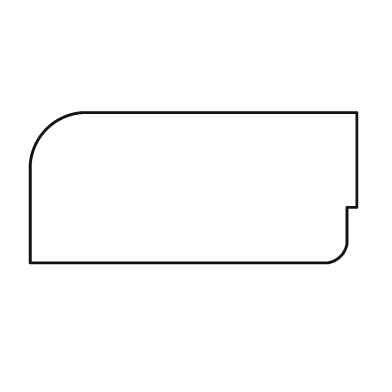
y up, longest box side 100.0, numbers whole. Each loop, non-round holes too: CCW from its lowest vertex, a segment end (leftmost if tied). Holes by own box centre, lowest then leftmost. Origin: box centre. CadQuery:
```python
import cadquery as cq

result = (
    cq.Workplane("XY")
    .moveTo(-50.0, -23.0)
    .lineTo(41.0, -23.0)
    .threePointArc((45.0, -21.0), (47.0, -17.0))
    .lineTo(47.0, -6.0)
    .lineTo(50.0, -6.0)
    .lineTo(50.0, 23.0)
    .lineTo(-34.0, 23.0)
    .threePointArc((-45.0, 18.0), (-50.0, 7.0))
    .close()
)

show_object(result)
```